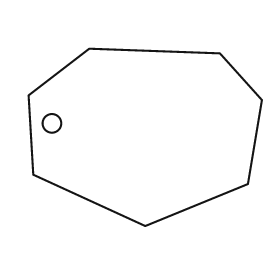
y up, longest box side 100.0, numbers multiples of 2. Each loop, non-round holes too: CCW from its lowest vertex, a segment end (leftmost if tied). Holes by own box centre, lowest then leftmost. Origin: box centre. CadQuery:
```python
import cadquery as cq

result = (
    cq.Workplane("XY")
    .moveTo(0.0, -38.0)
    .lineTo(44.0, -20.0)
    .lineTo(50.0, 16.0)
    .lineTo(32.0, 36.0)
    .lineTo(-24.0, 38.0)
    .lineTo(-50.0, 18.0)
    .lineTo(-48.0, -16.0)
    .close()
    .moveTo(-40.0, 6.0)
    .circle(4.0)
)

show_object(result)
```